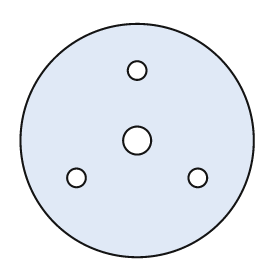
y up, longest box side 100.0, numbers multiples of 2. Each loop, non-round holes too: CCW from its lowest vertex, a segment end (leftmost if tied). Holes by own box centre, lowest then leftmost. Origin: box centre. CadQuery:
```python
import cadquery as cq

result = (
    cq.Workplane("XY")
    .moveTo(0.0, 0.0)
    .circle(50.0)
    .moveTo(-26.0, -16.0)
    .circle(4.0)
    .moveTo(26.0, -16.0)
    .circle(4.0)
    .moveTo(0.0, 0.0)
    .circle(6.0)
    .moveTo(0.0, 30.0)
    .circle(4.0)
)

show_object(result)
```